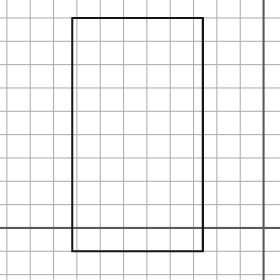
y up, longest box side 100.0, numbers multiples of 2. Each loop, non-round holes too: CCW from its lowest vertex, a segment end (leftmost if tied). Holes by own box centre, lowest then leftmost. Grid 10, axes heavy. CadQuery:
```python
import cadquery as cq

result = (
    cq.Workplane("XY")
    .moveTo(-82.0, -10.0)
    .lineTo(-26.0, -10.0)
    .lineTo(-26.0, 90.0)
    .lineTo(-82.0, 90.0)
    .close()
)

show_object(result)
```